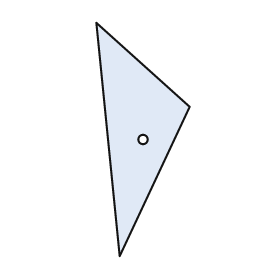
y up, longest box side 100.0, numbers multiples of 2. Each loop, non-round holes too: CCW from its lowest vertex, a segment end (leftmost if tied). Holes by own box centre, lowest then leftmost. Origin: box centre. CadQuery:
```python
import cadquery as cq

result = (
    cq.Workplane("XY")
    .moveTo(-10.0, -50.0)
    .lineTo(20.0, 14.0)
    .lineTo(-20.0, 50.0)
    .close()
    .moveTo(0.0, 0.0)
    .circle(2.0)
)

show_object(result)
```